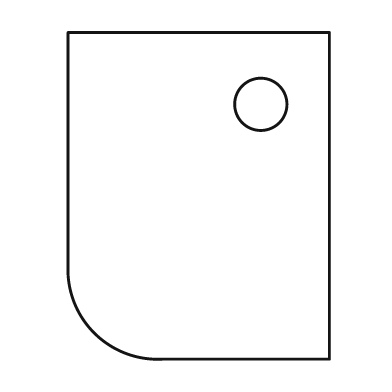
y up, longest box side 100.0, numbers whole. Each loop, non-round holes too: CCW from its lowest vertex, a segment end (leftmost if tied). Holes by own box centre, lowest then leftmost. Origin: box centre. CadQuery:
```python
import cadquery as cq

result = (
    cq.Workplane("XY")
    .moveTo(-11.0, -50.0)
    .lineTo(40.0, -50.0)
    .lineTo(40.0, 50.0)
    .lineTo(-40.0, 50.0)
    .lineTo(-40.0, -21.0)
    .threePointArc((-32.0, -42.0), (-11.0, -50.0))
    .close()
    .moveTo(19.0, 28.0)
    .circle(8.0)
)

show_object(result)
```